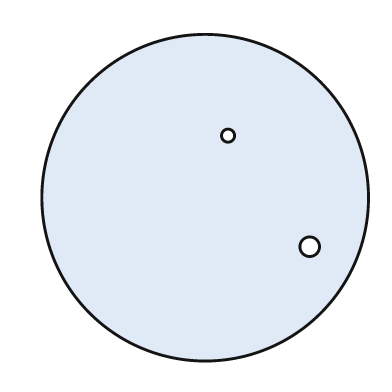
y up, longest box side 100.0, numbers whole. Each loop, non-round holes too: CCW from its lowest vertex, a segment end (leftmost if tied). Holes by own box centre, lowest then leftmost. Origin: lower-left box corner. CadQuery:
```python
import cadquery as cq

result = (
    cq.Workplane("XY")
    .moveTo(50.0, 50.0)
    .circle(50.0)
    .moveTo(82.0, 35.0)
    .circle(3.0)
    .moveTo(57.0, 69.0)
    .circle(2.0)
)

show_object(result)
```